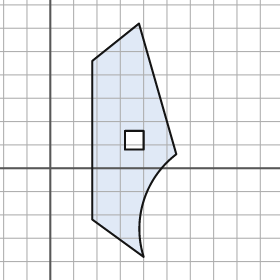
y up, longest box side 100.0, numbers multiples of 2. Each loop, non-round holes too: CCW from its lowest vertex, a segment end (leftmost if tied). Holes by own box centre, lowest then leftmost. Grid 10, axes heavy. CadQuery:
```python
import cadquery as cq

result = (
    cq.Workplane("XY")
    .moveTo(40.0, -38.0)
    .threePointArc((40.0, -14.0), (54.0, 6.0))
    .lineTo(38.0, 62.0)
    .lineTo(18.0, 46.0)
    .lineTo(18.0, -22.0)
    .close()
    .moveTo(32.0, 8.0)
    .lineTo(40.0, 8.0)
    .lineTo(40.0, 16.0)
    .lineTo(32.0, 16.0)
    .close()
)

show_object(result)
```